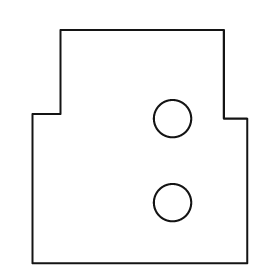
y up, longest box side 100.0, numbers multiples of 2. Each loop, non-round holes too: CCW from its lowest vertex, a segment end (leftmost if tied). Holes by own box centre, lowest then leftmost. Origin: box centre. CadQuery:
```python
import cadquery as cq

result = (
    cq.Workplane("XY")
    .moveTo(-46.0, -50.0)
    .lineTo(46.0, -50.0)
    .lineTo(46.0, 12.0)
    .lineTo(36.0, 12.0)
    .lineTo(36.0, 50.0)
    .lineTo(-34.0, 50.0)
    .lineTo(-34.0, 14.0)
    .lineTo(-46.0, 14.0)
    .close()
    .moveTo(14.0, -24.0)
    .circle(8.0)
    .moveTo(14.0, 12.0)
    .circle(8.0)
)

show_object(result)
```